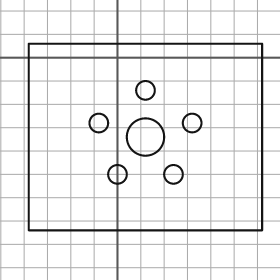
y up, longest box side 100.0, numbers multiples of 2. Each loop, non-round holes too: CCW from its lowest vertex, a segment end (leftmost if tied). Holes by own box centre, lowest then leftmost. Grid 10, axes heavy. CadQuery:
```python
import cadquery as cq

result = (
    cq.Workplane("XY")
    .moveTo(-38.0, -74.0)
    .lineTo(62.0, -74.0)
    .lineTo(62.0, 6.0)
    .lineTo(-38.0, 6.0)
    .close()
    .moveTo(0.0, -50.0)
    .circle(4.0)
    .moveTo(24.0, -50.0)
    .circle(4.0)
    .moveTo(12.0, -34.0)
    .circle(8.0)
    .moveTo(-8.0, -28.0)
    .circle(4.0)
    .moveTo(32.0, -28.0)
    .circle(4.0)
    .moveTo(12.0, -14.0)
    .circle(4.0)
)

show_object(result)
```